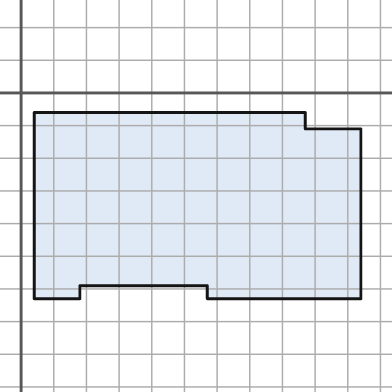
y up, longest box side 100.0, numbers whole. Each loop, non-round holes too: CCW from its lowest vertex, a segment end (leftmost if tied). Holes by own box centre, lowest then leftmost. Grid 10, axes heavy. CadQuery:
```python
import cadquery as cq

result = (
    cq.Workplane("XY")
    .moveTo(4.0, -63.0)
    .lineTo(18.0, -63.0)
    .lineTo(18.0, -59.0)
    .lineTo(57.0, -59.0)
    .lineTo(57.0, -63.0)
    .lineTo(104.0, -63.0)
    .lineTo(104.0, -11.0)
    .lineTo(87.0, -11.0)
    .lineTo(87.0, -6.0)
    .lineTo(4.0, -6.0)
    .close()
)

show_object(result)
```